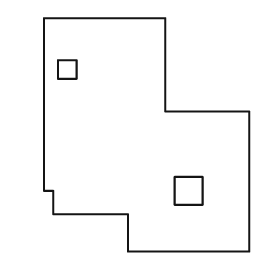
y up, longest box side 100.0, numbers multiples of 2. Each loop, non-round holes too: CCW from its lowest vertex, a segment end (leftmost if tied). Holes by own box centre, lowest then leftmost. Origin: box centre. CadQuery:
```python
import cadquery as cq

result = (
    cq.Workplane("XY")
    .moveTo(-8.0, -50.0)
    .lineTo(44.0, -50.0)
    .lineTo(44.0, 10.0)
    .lineTo(8.0, 10.0)
    .lineTo(8.0, 50.0)
    .lineTo(-44.0, 50.0)
    .lineTo(-44.0, -24.0)
    .lineTo(-40.0, -24.0)
    .lineTo(-40.0, -34.0)
    .lineTo(-8.0, -34.0)
    .close()
    .moveTo(12.0, -30.0)
    .lineTo(24.0, -30.0)
    .lineTo(24.0, -18.0)
    .lineTo(12.0, -18.0)
    .close()
    .moveTo(-38.0, 24.0)
    .lineTo(-30.0, 24.0)
    .lineTo(-30.0, 32.0)
    .lineTo(-38.0, 32.0)
    .close()
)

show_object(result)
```